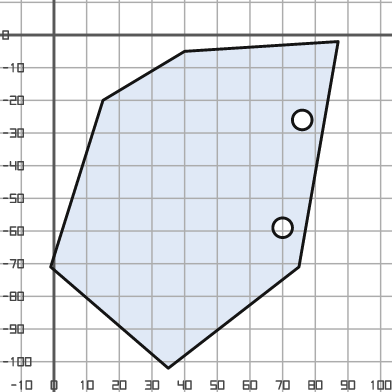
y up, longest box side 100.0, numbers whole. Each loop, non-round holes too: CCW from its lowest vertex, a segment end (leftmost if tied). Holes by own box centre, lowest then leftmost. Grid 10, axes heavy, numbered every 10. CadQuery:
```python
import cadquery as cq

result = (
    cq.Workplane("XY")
    .moveTo(35.0, -102.0)
    .lineTo(75.0, -71.0)
    .lineTo(87.0, -2.0)
    .lineTo(40.0, -5.0)
    .lineTo(15.0, -20.0)
    .lineTo(-1.0, -71.0)
    .close()
    .moveTo(70.0, -59.0)
    .circle(3.0)
    .moveTo(76.0, -26.0)
    .circle(3.0)
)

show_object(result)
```